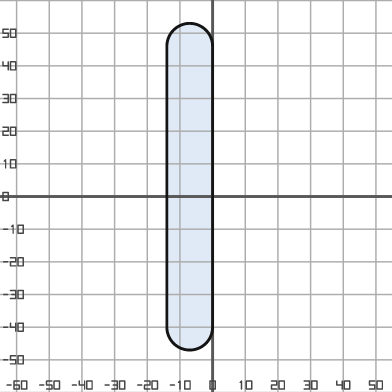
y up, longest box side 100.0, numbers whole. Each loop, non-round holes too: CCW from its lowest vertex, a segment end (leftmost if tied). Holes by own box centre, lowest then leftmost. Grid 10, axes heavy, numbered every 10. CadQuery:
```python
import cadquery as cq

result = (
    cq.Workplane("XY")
    .moveTo(-14.0, -40.0)
    .threePointArc((-7.0, -47.0), (0.0, -40.0))
    .lineTo(0.0, 46.0)
    .threePointArc((-7.0, 53.0), (-14.0, 46.0))
    .close()
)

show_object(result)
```